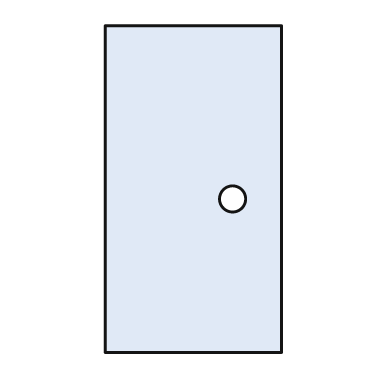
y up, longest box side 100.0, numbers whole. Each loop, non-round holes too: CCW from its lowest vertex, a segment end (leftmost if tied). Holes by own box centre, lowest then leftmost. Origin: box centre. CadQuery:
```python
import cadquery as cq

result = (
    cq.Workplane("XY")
    .moveTo(-27.0, -50.0)
    .lineTo(27.0, -50.0)
    .lineTo(27.0, 50.0)
    .lineTo(-27.0, 50.0)
    .close()
    .moveTo(12.0, -3.0)
    .circle(4.0)
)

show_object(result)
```